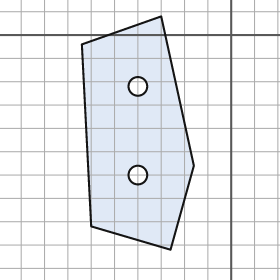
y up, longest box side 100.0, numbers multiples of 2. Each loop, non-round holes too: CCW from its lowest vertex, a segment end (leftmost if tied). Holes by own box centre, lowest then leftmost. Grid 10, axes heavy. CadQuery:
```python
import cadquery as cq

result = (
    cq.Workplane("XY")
    .moveTo(-26.0, -92.0)
    .lineTo(-16.0, -56.0)
    .lineTo(-30.0, 8.0)
    .lineTo(-64.0, -4.0)
    .lineTo(-60.0, -82.0)
    .close()
    .moveTo(-40.0, -60.0)
    .circle(4.0)
    .moveTo(-40.0, -22.0)
    .circle(4.0)
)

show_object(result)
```